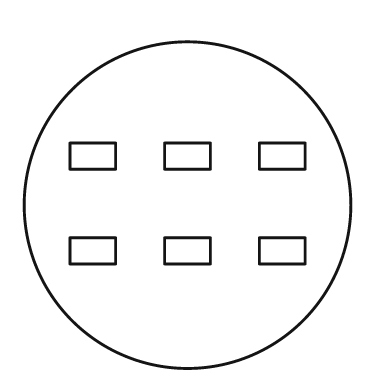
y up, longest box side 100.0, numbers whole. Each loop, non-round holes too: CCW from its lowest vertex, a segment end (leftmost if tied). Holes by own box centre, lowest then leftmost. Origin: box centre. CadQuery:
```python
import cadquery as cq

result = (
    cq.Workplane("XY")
    .moveTo(0.0, 0.0)
    .circle(50.0)
    .moveTo(-36.0, -18.0)
    .lineTo(-22.0, -18.0)
    .lineTo(-22.0, -10.0)
    .lineTo(-36.0, -10.0)
    .close()
    .moveTo(-7.0, -18.0)
    .lineTo(7.0, -18.0)
    .lineTo(7.0, -10.0)
    .lineTo(-7.0, -10.0)
    .close()
    .moveTo(22.0, -18.0)
    .lineTo(36.0, -18.0)
    .lineTo(36.0, -10.0)
    .lineTo(22.0, -10.0)
    .close()
    .moveTo(-36.0, 11.0)
    .lineTo(-22.0, 11.0)
    .lineTo(-22.0, 19.0)
    .lineTo(-36.0, 19.0)
    .close()
    .moveTo(-7.0, 11.0)
    .lineTo(7.0, 11.0)
    .lineTo(7.0, 19.0)
    .lineTo(-7.0, 19.0)
    .close()
    .moveTo(22.0, 11.0)
    .lineTo(36.0, 11.0)
    .lineTo(36.0, 19.0)
    .lineTo(22.0, 19.0)
    .close()
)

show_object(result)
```